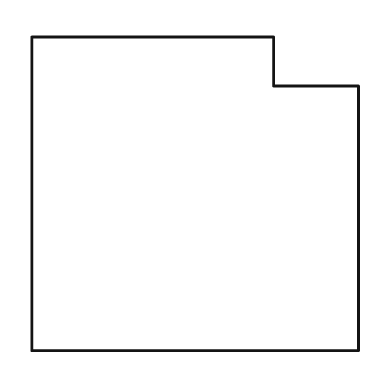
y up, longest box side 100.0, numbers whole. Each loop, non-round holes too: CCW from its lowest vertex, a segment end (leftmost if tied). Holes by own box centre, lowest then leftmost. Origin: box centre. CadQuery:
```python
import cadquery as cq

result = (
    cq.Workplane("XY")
    .moveTo(-50.0, -48.0)
    .lineTo(50.0, -48.0)
    .lineTo(50.0, 33.0)
    .lineTo(24.0, 33.0)
    .lineTo(24.0, 48.0)
    .lineTo(-50.0, 48.0)
    .close()
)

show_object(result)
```